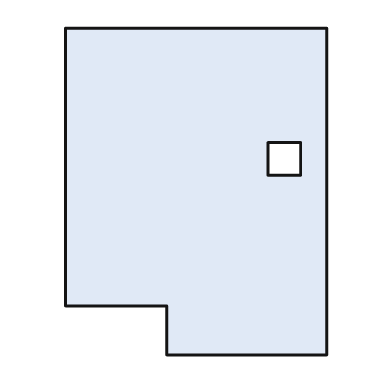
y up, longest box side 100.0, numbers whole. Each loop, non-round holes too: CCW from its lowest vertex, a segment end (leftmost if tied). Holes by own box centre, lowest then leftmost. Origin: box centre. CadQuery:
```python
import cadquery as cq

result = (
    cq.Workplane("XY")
    .moveTo(-9.0, -50.0)
    .lineTo(40.0, -50.0)
    .lineTo(40.0, 50.0)
    .lineTo(-40.0, 50.0)
    .lineTo(-40.0, -35.0)
    .lineTo(-9.0, -35.0)
    .close()
    .moveTo(22.0, 5.0)
    .lineTo(32.0, 5.0)
    .lineTo(32.0, 15.0)
    .lineTo(22.0, 15.0)
    .close()
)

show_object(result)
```